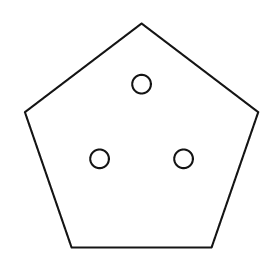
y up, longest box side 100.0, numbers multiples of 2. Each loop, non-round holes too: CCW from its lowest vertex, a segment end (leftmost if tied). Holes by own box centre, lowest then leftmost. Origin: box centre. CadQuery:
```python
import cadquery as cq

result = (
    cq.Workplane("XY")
    .moveTo(-30.0, -48.0)
    .lineTo(30.0, -48.0)
    .lineTo(50.0, 10.0)
    .lineTo(0.0, 48.0)
    .lineTo(-50.0, 10.0)
    .close()
    .moveTo(-18.0, -10.0)
    .circle(4.0)
    .moveTo(18.0, -10.0)
    .circle(4.0)
    .moveTo(0.0, 22.0)
    .circle(4.0)
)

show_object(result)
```